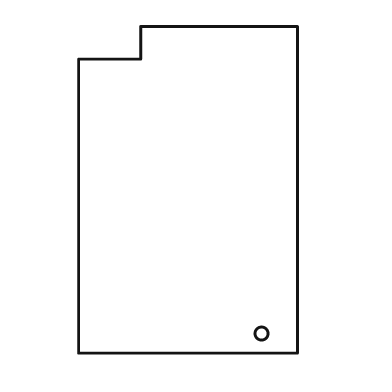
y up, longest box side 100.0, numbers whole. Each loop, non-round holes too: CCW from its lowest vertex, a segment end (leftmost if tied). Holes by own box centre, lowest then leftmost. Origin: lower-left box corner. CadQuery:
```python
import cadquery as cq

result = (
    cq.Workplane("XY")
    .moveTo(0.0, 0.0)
    .lineTo(67.0, 0.0)
    .lineTo(67.0, 100.0)
    .lineTo(19.0, 100.0)
    .lineTo(19.0, 90.0)
    .lineTo(0.0, 90.0)
    .close()
    .moveTo(56.0, 6.0)
    .circle(2.0)
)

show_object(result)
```